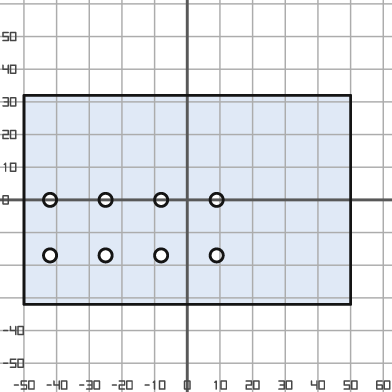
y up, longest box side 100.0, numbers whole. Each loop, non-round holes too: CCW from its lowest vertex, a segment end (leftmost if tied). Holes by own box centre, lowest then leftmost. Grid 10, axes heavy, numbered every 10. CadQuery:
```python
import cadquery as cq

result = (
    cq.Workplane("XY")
    .moveTo(-50.0, -32.0)
    .lineTo(50.0, -32.0)
    .lineTo(50.0, 32.0)
    .lineTo(-50.0, 32.0)
    .close()
    .moveTo(-42.0, -17.0)
    .circle(2.0)
    .moveTo(-25.0, -17.0)
    .circle(2.0)
    .moveTo(-8.0, -17.0)
    .circle(2.0)
    .moveTo(9.0, -17.0)
    .circle(2.0)
    .moveTo(-42.0, 0.0)
    .circle(2.0)
    .moveTo(-25.0, 0.0)
    .circle(2.0)
    .moveTo(-8.0, 0.0)
    .circle(2.0)
    .moveTo(9.0, 0.0)
    .circle(2.0)
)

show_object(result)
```